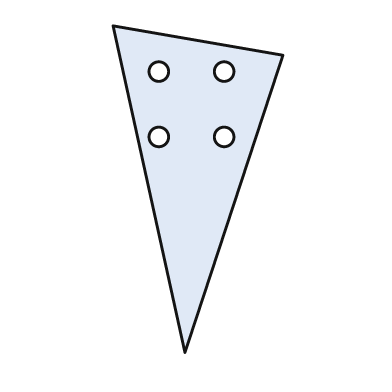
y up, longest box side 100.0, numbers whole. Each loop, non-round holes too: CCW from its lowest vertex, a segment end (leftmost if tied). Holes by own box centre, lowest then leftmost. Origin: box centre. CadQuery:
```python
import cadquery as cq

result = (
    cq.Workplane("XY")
    .moveTo(-4.0, -50.0)
    .lineTo(26.0, 41.0)
    .lineTo(-26.0, 50.0)
    .close()
    .moveTo(-12.0, 16.0)
    .circle(3.0)
    .moveTo(8.0, 16.0)
    .circle(3.0)
    .moveTo(-12.0, 36.0)
    .circle(3.0)
    .moveTo(8.0, 36.0)
    .circle(3.0)
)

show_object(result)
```